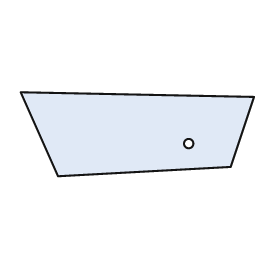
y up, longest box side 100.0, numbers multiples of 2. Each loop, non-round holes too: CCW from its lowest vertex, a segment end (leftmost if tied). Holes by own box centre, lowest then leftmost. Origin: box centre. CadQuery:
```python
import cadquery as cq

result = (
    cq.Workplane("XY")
    .moveTo(-34.0, -18.0)
    .lineTo(40.0, -14.0)
    .lineTo(50.0, 16.0)
    .lineTo(-50.0, 18.0)
    .close()
    .moveTo(22.0, -4.0)
    .circle(2.0)
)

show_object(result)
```